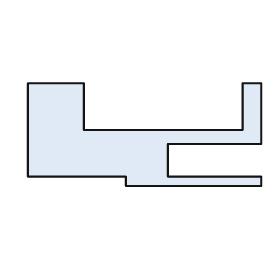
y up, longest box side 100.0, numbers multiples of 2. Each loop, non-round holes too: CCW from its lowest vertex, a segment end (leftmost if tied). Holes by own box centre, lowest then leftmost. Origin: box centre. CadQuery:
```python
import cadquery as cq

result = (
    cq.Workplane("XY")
    .moveTo(-8.0, -22.0)
    .lineTo(50.0, -22.0)
    .lineTo(50.0, -18.0)
    .lineTo(10.0, -18.0)
    .lineTo(10.0, -4.0)
    .lineTo(50.0, -4.0)
    .lineTo(50.0, 22.0)
    .lineTo(42.0, 22.0)
    .lineTo(42.0, 2.0)
    .lineTo(-26.0, 2.0)
    .lineTo(-26.0, 22.0)
    .lineTo(-50.0, 22.0)
    .lineTo(-50.0, -18.0)
    .lineTo(-8.0, -18.0)
    .close()
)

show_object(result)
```